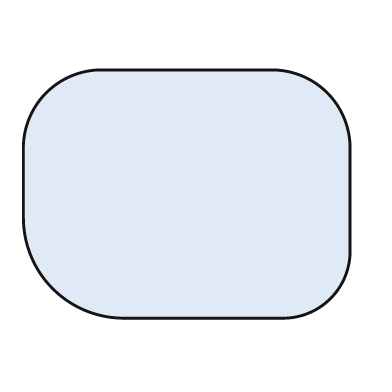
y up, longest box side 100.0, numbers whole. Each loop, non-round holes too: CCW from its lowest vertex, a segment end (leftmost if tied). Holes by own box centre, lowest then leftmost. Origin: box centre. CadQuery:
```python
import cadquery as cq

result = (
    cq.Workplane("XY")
    .moveTo(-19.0, -38.0)
    .lineTo(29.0, -38.0)
    .threePointArc((44.0, -32.0), (50.0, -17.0))
    .lineTo(50.0, 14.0)
    .threePointArc((43.0, 31.0), (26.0, 38.0))
    .lineTo(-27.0, 38.0)
    .threePointArc((-43.0, 31.0), (-50.0, 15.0))
    .lineTo(-50.0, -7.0)
    .threePointArc((-41.0, -29.0), (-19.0, -38.0))
    .close()
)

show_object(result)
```